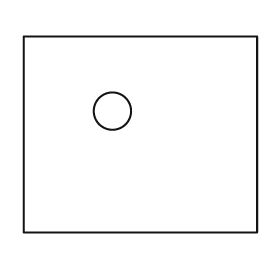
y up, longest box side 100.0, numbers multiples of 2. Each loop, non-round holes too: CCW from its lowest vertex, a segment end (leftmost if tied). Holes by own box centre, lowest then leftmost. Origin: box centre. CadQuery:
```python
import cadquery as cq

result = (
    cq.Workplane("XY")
    .moveTo(-50.0, -42.0)
    .lineTo(50.0, -42.0)
    .lineTo(50.0, 42.0)
    .lineTo(-50.0, 42.0)
    .close()
    .moveTo(-12.0, 10.0)
    .circle(8.0)
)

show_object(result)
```